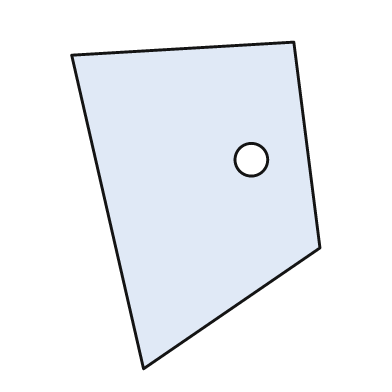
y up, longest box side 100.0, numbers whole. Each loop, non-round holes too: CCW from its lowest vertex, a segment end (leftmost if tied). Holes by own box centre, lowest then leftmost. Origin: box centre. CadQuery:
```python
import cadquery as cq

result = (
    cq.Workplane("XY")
    .moveTo(-16.0, -50.0)
    .lineTo(38.0, -13.0)
    .lineTo(30.0, 50.0)
    .lineTo(-38.0, 46.0)
    .close()
    .moveTo(17.0, 14.0)
    .circle(5.0)
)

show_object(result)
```